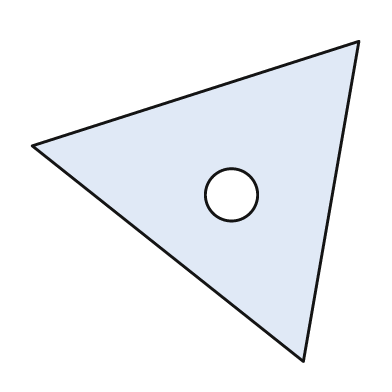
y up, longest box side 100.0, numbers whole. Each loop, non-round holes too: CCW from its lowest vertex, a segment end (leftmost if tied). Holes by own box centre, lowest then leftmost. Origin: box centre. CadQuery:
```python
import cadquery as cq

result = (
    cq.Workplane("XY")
    .moveTo(33.0, -49.0)
    .lineTo(50.0, 49.0)
    .lineTo(-50.0, 17.0)
    .close()
    .moveTo(11.0, 2.0)
    .circle(8.0)
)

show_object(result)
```